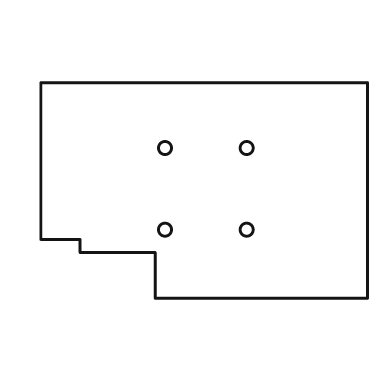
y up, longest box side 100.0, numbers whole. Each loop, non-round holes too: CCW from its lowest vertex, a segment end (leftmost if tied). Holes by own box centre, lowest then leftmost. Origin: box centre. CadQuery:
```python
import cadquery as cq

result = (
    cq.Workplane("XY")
    .moveTo(-15.0, -33.0)
    .lineTo(50.0, -33.0)
    .lineTo(50.0, 33.0)
    .lineTo(-50.0, 33.0)
    .lineTo(-50.0, -15.0)
    .lineTo(-38.0, -15.0)
    .lineTo(-38.0, -19.0)
    .lineTo(-15.0, -19.0)
    .close()
    .moveTo(-12.0, -12.0)
    .circle(2.0)
    .moveTo(13.0, -12.0)
    .circle(2.0)
    .moveTo(-12.0, 13.0)
    .circle(2.0)
    .moveTo(13.0, 13.0)
    .circle(2.0)
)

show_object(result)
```